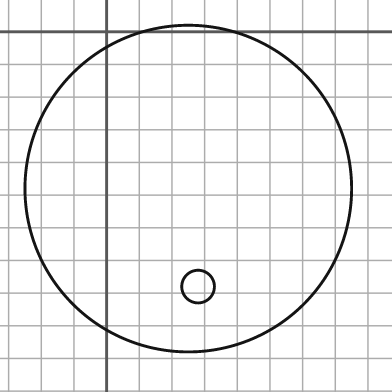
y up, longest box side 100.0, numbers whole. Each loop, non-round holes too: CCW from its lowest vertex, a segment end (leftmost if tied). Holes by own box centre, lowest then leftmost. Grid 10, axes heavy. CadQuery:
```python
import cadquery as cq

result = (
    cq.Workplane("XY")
    .moveTo(25.0, -48.0)
    .circle(50.0)
    .moveTo(28.0, -78.0)
    .circle(5.0)
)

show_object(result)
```